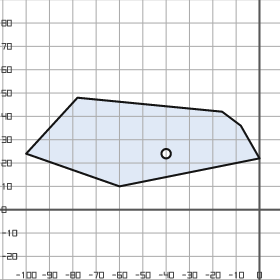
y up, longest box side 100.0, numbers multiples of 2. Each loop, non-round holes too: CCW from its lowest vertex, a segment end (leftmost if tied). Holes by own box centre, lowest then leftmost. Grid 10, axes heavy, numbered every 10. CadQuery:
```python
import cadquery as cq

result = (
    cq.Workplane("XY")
    .moveTo(-60.0, 10.0)
    .lineTo(0.0, 22.0)
    .lineTo(-8.0, 36.0)
    .lineTo(-16.0, 42.0)
    .lineTo(-78.0, 48.0)
    .lineTo(-100.0, 24.0)
    .close()
    .moveTo(-40.0, 24.0)
    .circle(2.0)
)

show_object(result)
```